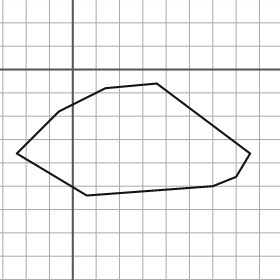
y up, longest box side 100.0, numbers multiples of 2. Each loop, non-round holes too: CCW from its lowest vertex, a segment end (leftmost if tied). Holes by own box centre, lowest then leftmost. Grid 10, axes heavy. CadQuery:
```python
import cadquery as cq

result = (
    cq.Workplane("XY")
    .moveTo(6.0, -54.0)
    .lineTo(60.0, -50.0)
    .lineTo(70.0, -46.0)
    .lineTo(76.0, -36.0)
    .lineTo(36.0, -6.0)
    .lineTo(14.0, -8.0)
    .lineTo(-6.0, -18.0)
    .lineTo(-24.0, -36.0)
    .close()
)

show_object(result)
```